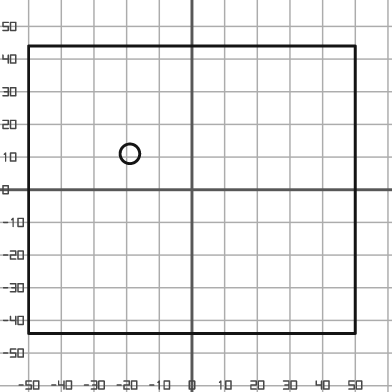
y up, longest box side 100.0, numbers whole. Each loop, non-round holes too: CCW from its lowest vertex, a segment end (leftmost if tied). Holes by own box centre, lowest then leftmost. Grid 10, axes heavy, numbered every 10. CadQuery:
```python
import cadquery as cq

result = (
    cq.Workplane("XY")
    .moveTo(-50.0, -44.0)
    .lineTo(50.0, -44.0)
    .lineTo(50.0, 44.0)
    .lineTo(-50.0, 44.0)
    .close()
    .moveTo(-19.0, 11.0)
    .circle(3.0)
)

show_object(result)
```